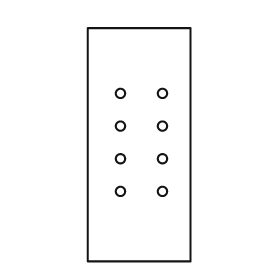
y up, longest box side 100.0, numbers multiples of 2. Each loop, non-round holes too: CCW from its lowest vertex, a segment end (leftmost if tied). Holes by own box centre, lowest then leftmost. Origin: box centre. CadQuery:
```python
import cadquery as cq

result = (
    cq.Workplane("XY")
    .moveTo(-22.0, -50.0)
    .lineTo(22.0, -50.0)
    .lineTo(22.0, 50.0)
    .lineTo(-22.0, 50.0)
    .close()
    .moveTo(-8.0, -20.0)
    .circle(2.0)
    .moveTo(10.0, -20.0)
    .circle(2.0)
    .moveTo(-8.0, -6.0)
    .circle(2.0)
    .moveTo(10.0, -6.0)
    .circle(2.0)
    .moveTo(-8.0, 8.0)
    .circle(2.0)
    .moveTo(10.0, 8.0)
    .circle(2.0)
    .moveTo(-8.0, 22.0)
    .circle(2.0)
    .moveTo(10.0, 22.0)
    .circle(2.0)
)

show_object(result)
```